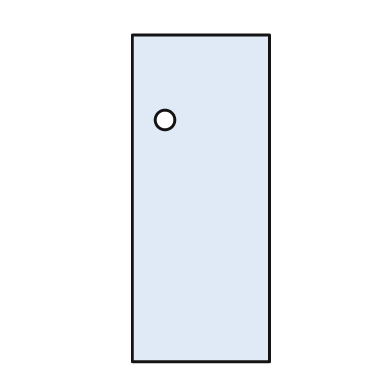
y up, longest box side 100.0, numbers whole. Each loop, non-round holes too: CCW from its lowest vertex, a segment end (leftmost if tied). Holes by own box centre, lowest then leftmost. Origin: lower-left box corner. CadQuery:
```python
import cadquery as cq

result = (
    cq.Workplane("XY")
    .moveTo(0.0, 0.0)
    .lineTo(42.0, 0.0)
    .lineTo(42.0, 100.0)
    .lineTo(0.0, 100.0)
    .close()
    .moveTo(10.0, 74.0)
    .circle(3.0)
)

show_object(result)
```